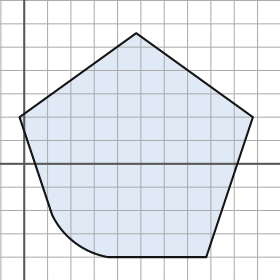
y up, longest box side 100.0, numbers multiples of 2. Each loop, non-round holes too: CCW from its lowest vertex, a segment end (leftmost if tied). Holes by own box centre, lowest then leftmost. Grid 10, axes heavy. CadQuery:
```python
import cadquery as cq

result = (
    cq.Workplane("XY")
    .moveTo(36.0, -40.0)
    .lineTo(78.0, -40.0)
    .lineTo(98.0, 20.0)
    .lineTo(48.0, 56.0)
    .lineTo(-2.0, 20.0)
    .lineTo(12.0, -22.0)
    .threePointArc((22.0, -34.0), (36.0, -40.0))
    .close()
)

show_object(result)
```